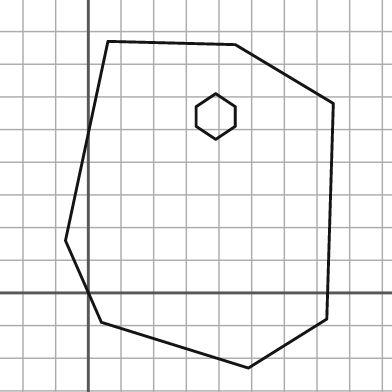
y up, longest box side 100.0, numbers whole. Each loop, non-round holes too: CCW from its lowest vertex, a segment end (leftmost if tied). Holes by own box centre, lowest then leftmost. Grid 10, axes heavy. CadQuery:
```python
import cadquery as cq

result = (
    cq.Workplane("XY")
    .moveTo(49.0, -23.0)
    .lineTo(73.0, -8.0)
    .lineTo(75.0, 58.0)
    .lineTo(45.0, 76.0)
    .lineTo(6.0, 77.0)
    .lineTo(-7.0, 16.0)
    .lineTo(4.0, -9.0)
    .close()
    .moveTo(39.0, 47.0)
    .lineTo(45.0, 51.0)
    .lineTo(45.0, 57.0)
    .lineTo(39.0, 61.0)
    .lineTo(33.0, 57.0)
    .lineTo(33.0, 51.0)
    .close()
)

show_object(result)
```